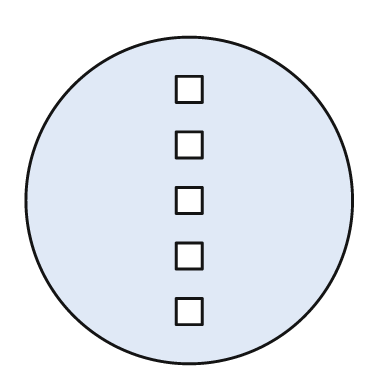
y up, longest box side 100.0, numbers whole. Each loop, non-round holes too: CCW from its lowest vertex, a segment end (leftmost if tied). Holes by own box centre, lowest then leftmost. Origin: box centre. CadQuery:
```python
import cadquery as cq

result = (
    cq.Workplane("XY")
    .moveTo(0.0, 0.0)
    .circle(50.0)
    .moveTo(-4.0, -38.0)
    .lineTo(4.0, -38.0)
    .lineTo(4.0, -30.0)
    .lineTo(-4.0, -30.0)
    .close()
    .moveTo(-4.0, -21.0)
    .lineTo(4.0, -21.0)
    .lineTo(4.0, -13.0)
    .lineTo(-4.0, -13.0)
    .close()
    .moveTo(-4.0, -4.0)
    .lineTo(4.0, -4.0)
    .lineTo(4.0, 4.0)
    .lineTo(-4.0, 4.0)
    .close()
    .moveTo(-4.0, 13.0)
    .lineTo(4.0, 13.0)
    .lineTo(4.0, 21.0)
    .lineTo(-4.0, 21.0)
    .close()
    .moveTo(-4.0, 30.0)
    .lineTo(4.0, 30.0)
    .lineTo(4.0, 38.0)
    .lineTo(-4.0, 38.0)
    .close()
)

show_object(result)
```